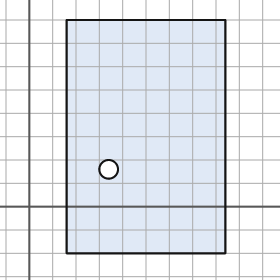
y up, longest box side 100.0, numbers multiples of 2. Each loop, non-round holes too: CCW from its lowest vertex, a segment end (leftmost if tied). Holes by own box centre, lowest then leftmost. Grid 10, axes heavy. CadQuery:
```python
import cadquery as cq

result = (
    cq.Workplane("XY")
    .moveTo(16.0, -20.0)
    .lineTo(84.0, -20.0)
    .lineTo(84.0, 80.0)
    .lineTo(16.0, 80.0)
    .close()
    .moveTo(34.0, 16.0)
    .circle(4.0)
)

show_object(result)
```